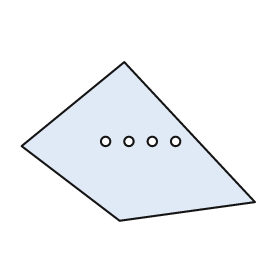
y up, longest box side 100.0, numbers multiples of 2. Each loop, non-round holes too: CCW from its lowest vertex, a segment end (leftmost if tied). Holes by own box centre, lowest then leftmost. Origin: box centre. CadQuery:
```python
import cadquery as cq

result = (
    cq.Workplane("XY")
    .moveTo(-8.0, -34.0)
    .lineTo(50.0, -26.0)
    .lineTo(-6.0, 34.0)
    .lineTo(-50.0, -2.0)
    .close()
    .moveTo(-14.0, 0.0)
    .circle(2.0)
    .moveTo(-4.0, 0.0)
    .circle(2.0)
    .moveTo(6.0, 0.0)
    .circle(2.0)
    .moveTo(16.0, 0.0)
    .circle(2.0)
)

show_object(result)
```